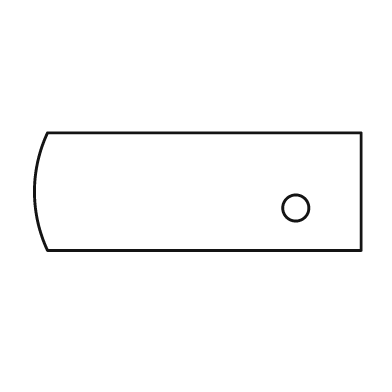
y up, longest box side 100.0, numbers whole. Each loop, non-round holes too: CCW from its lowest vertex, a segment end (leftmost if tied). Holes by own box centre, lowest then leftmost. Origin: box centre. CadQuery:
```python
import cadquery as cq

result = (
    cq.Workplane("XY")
    .moveTo(-46.0, -18.0)
    .lineTo(50.0, -18.0)
    .lineTo(50.0, 18.0)
    .lineTo(-46.0, 18.0)
    .threePointArc((-50.0, 0.0), (-46.0, -18.0))
    .close()
    .moveTo(30.0, -5.0)
    .circle(4.0)
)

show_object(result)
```